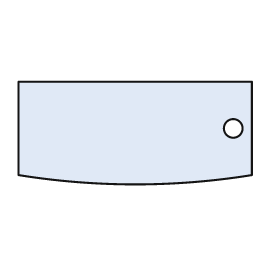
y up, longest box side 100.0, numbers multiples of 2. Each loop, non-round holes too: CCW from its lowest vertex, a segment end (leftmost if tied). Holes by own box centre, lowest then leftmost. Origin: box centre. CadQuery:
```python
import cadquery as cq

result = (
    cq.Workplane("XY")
    .moveTo(-50.0, -18.0)
    .threePointArc((0.0, -22.0), (50.0, -18.0))
    .lineTo(50.0, 22.0)
    .lineTo(-50.0, 22.0)
    .close()
    .moveTo(42.0, 2.0)
    .circle(4.0)
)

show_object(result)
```